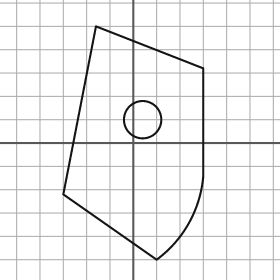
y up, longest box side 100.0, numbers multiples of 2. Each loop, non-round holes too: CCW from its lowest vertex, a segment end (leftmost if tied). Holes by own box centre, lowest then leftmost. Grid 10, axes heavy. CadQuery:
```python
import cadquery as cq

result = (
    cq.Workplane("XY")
    .moveTo(10.0, -50.0)
    .threePointArc((24.0, -34.0), (30.0, -14.0))
    .lineTo(30.0, 32.0)
    .lineTo(-16.0, 50.0)
    .lineTo(-30.0, -22.0)
    .close()
    .moveTo(4.0, 10.0)
    .circle(8.0)
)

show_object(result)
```